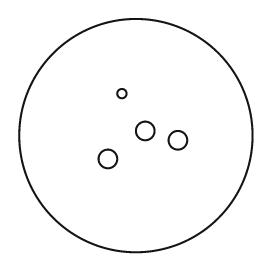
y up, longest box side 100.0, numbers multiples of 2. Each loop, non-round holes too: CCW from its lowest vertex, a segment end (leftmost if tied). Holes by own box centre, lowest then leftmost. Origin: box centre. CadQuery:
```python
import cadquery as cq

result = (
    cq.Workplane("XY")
    .moveTo(0.0, 0.0)
    .circle(50.0)
    .moveTo(-12.0, -10.0)
    .circle(4.0)
    .moveTo(18.0, -2.0)
    .circle(4.0)
    .moveTo(4.0, 2.0)
    .circle(4.0)
    .moveTo(-6.0, 18.0)
    .circle(2.0)
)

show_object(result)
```